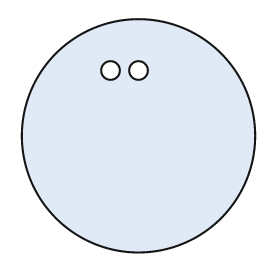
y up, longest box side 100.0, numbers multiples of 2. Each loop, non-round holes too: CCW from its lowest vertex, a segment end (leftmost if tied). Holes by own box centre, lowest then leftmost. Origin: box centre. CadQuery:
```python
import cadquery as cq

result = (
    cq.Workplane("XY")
    .moveTo(0.0, 0.0)
    .circle(50.0)
    .moveTo(-12.0, 28.0)
    .circle(4.0)
    .moveTo(0.0, 28.0)
    .circle(4.0)
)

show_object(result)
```